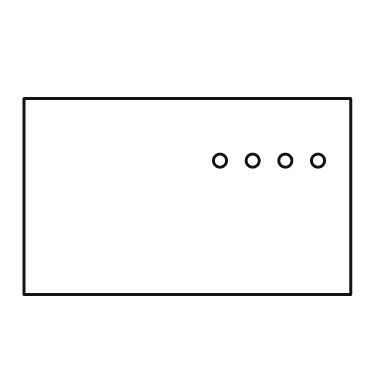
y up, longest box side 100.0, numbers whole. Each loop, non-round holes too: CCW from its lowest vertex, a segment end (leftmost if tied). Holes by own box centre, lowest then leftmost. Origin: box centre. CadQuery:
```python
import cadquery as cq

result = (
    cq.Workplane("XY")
    .moveTo(-50.0, -30.0)
    .lineTo(50.0, -30.0)
    .lineTo(50.0, 30.0)
    .lineTo(-50.0, 30.0)
    .close()
    .moveTo(10.0, 11.0)
    .circle(2.0)
    .moveTo(20.0, 11.0)
    .circle(2.0)
    .moveTo(30.0, 11.0)
    .circle(2.0)
    .moveTo(40.0, 11.0)
    .circle(2.0)
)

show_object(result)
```